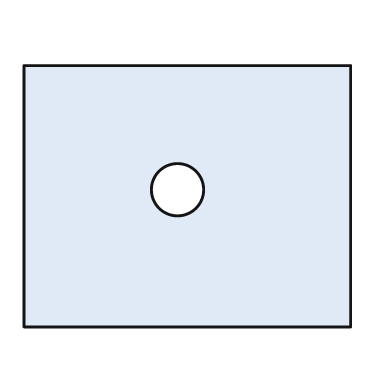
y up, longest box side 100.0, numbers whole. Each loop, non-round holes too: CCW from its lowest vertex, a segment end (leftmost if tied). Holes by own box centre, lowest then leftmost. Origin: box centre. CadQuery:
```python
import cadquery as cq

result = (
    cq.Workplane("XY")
    .moveTo(-50.0, -40.0)
    .lineTo(50.0, -40.0)
    .lineTo(50.0, 40.0)
    .lineTo(-50.0, 40.0)
    .close()
    .moveTo(-3.0, 2.0)
    .circle(8.0)
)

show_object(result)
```